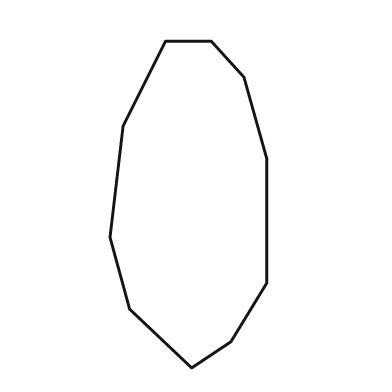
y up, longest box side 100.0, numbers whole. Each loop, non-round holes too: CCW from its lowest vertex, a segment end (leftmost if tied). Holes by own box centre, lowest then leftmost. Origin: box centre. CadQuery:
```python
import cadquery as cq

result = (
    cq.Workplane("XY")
    .moveTo(1.0, -50.0)
    .lineTo(13.0, -42.0)
    .lineTo(24.0, -24.0)
    .lineTo(24.0, 14.0)
    .lineTo(17.0, 39.0)
    .lineTo(7.0, 50.0)
    .lineTo(-7.0, 50.0)
    .lineTo(-20.0, 24.0)
    .lineTo(-24.0, -10.0)
    .lineTo(-18.0, -32.0)
    .close()
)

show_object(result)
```